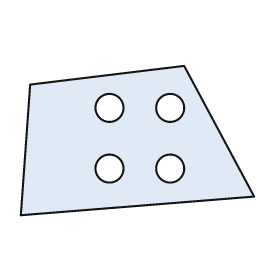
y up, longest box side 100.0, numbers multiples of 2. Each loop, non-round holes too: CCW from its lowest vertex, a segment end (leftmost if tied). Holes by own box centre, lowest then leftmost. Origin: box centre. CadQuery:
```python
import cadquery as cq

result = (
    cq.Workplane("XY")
    .moveTo(-50.0, -32.0)
    .lineTo(50.0, -24.0)
    .lineTo(20.0, 32.0)
    .lineTo(-46.0, 24.0)
    .close()
    .moveTo(-12.0, -12.0)
    .circle(6.0)
    .moveTo(14.0, -12.0)
    .circle(6.0)
    .moveTo(-12.0, 14.0)
    .circle(6.0)
    .moveTo(14.0, 14.0)
    .circle(6.0)
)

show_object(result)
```